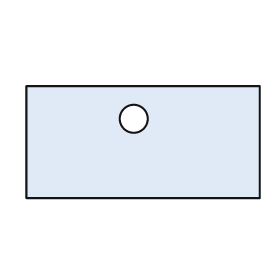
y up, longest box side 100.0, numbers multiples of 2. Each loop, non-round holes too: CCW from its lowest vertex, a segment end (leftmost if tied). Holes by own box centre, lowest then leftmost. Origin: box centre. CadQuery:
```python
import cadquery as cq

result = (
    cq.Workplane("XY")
    .moveTo(-50.0, -24.0)
    .lineTo(50.0, -24.0)
    .lineTo(50.0, 24.0)
    .lineTo(-50.0, 24.0)
    .close()
    .moveTo(-4.0, 10.0)
    .circle(6.0)
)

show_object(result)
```